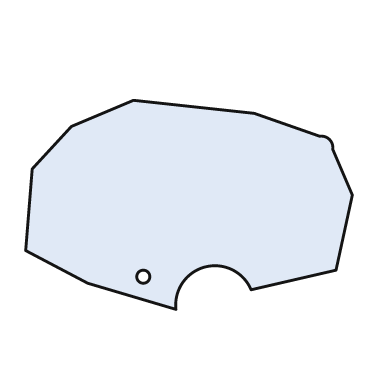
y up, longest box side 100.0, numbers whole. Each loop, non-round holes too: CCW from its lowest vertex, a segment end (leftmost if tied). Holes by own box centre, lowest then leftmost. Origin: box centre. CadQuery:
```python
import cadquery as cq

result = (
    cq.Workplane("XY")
    .moveTo(-4.0, -32.0)
    .threePointArc((5.0, -19.0), (19.0, -26.0))
    .lineTo(45.0, -20.0)
    .lineTo(50.0, 3.0)
    .lineTo(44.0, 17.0)
    .threePointArc((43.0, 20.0), (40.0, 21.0))
    .lineTo(20.0, 28.0)
    .lineTo(-17.0, 32.0)
    .lineTo(-36.0, 24.0)
    .lineTo(-48.0, 11.0)
    .lineTo(-50.0, -14.0)
    .lineTo(-31.0, -24.0)
    .close()
    .moveTo(-14.0, -22.0)
    .circle(2.0)
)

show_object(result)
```